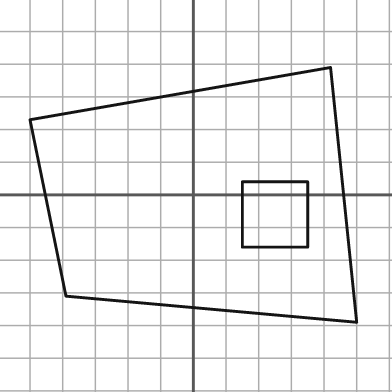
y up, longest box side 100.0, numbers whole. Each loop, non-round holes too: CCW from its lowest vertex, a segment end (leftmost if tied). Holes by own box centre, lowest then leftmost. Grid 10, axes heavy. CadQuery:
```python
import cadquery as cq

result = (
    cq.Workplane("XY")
    .moveTo(50.0, -39.0)
    .lineTo(42.0, 39.0)
    .lineTo(-50.0, 23.0)
    .lineTo(-39.0, -31.0)
    .close()
    .moveTo(15.0, -16.0)
    .lineTo(35.0, -16.0)
    .lineTo(35.0, 4.0)
    .lineTo(15.0, 4.0)
    .close()
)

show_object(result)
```